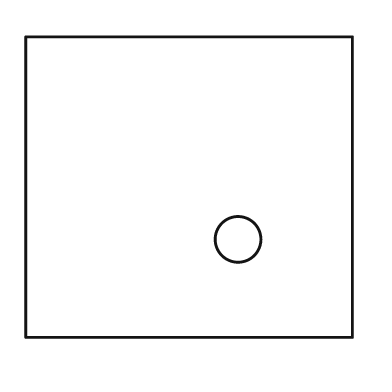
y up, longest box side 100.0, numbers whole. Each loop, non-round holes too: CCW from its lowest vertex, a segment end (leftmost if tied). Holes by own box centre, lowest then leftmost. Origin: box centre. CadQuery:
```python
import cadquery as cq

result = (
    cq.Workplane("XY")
    .moveTo(-50.0, -46.0)
    .lineTo(50.0, -46.0)
    .lineTo(50.0, 46.0)
    .lineTo(-50.0, 46.0)
    .close()
    .moveTo(15.0, -16.0)
    .circle(7.0)
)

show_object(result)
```